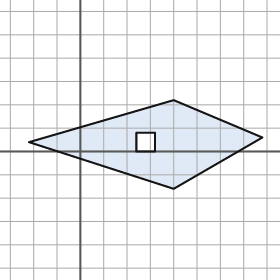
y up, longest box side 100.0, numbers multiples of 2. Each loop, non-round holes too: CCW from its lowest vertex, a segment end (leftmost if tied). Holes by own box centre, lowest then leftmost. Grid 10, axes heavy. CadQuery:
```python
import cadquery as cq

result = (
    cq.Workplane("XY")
    .moveTo(40.0, -16.0)
    .lineTo(78.0, 6.0)
    .lineTo(40.0, 22.0)
    .lineTo(-22.0, 4.0)
    .close()
    .moveTo(24.0, 0.0)
    .lineTo(32.0, 0.0)
    .lineTo(32.0, 8.0)
    .lineTo(24.0, 8.0)
    .close()
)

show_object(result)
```